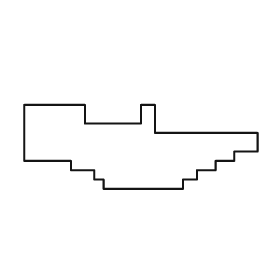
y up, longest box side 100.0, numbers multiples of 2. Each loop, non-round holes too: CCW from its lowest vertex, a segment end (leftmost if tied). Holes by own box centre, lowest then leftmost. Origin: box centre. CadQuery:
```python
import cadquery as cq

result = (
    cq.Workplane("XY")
    .moveTo(-16.0, -18.0)
    .lineTo(18.0, -18.0)
    .lineTo(18.0, -14.0)
    .lineTo(24.0, -14.0)
    .lineTo(24.0, -10.0)
    .lineTo(32.0, -10.0)
    .lineTo(32.0, -6.0)
    .lineTo(40.0, -6.0)
    .lineTo(40.0, -2.0)
    .lineTo(50.0, -2.0)
    .lineTo(50.0, 6.0)
    .lineTo(6.0, 6.0)
    .lineTo(6.0, 18.0)
    .lineTo(0.0, 18.0)
    .lineTo(0.0, 10.0)
    .lineTo(-24.0, 10.0)
    .lineTo(-24.0, 18.0)
    .lineTo(-50.0, 18.0)
    .lineTo(-50.0, -6.0)
    .lineTo(-30.0, -6.0)
    .lineTo(-30.0, -10.0)
    .lineTo(-20.0, -10.0)
    .lineTo(-20.0, -14.0)
    .lineTo(-16.0, -14.0)
    .close()
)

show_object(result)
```